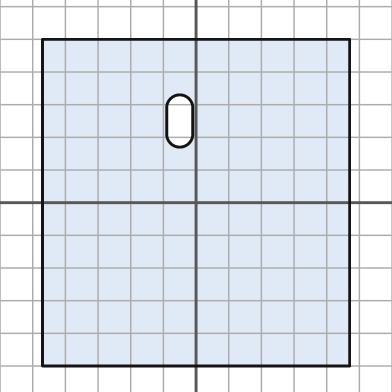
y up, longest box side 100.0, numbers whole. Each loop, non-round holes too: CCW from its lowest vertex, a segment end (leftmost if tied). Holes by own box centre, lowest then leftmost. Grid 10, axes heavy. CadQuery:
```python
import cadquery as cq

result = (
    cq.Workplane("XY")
    .moveTo(-47.0, -50.0)
    .lineTo(47.0, -50.0)
    .lineTo(47.0, 50.0)
    .lineTo(-47.0, 50.0)
    .close()
    .moveTo(-9.0, 21.0)
    .threePointArc((-5.0, 17.0), (-1.0, 21.0))
    .lineTo(-1.0, 29.0)
    .threePointArc((-5.0, 33.0), (-9.0, 29.0))
    .close()
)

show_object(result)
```